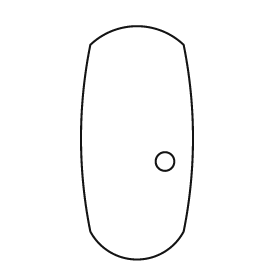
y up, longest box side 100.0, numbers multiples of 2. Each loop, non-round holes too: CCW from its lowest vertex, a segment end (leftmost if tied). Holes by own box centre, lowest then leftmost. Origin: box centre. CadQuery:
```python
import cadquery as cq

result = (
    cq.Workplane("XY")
    .moveTo(-20.0, -38.0)
    .threePointArc((0.0, -50.0), (20.0, -38.0))
    .threePointArc((24.0, 2.0), (20.0, 42.0))
    .threePointArc((0.0, 50.0), (-20.0, 42.0))
    .threePointArc((-24.0, 2.0), (-20.0, -38.0))
    .close()
    .moveTo(12.0, -8.0)
    .circle(4.0)
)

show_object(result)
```